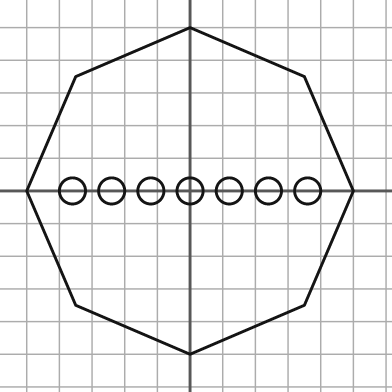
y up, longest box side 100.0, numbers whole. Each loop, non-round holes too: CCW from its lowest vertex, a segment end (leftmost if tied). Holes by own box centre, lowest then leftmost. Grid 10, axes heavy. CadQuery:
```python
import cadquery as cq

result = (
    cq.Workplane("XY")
    .moveTo(0.0, -50.0)
    .lineTo(35.0, -35.0)
    .lineTo(50.0, 0.0)
    .lineTo(35.0, 35.0)
    .lineTo(0.0, 50.0)
    .lineTo(-35.0, 35.0)
    .lineTo(-50.0, 0.0)
    .lineTo(-35.0, -35.0)
    .close()
    .moveTo(-36.0, 0.0)
    .circle(4.0)
    .moveTo(-24.0, 0.0)
    .circle(4.0)
    .moveTo(-12.0, 0.0)
    .circle(4.0)
    .moveTo(0.0, 0.0)
    .circle(4.0)
    .moveTo(12.0, 0.0)
    .circle(4.0)
    .moveTo(24.0, 0.0)
    .circle(4.0)
    .moveTo(36.0, 0.0)
    .circle(4.0)
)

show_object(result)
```